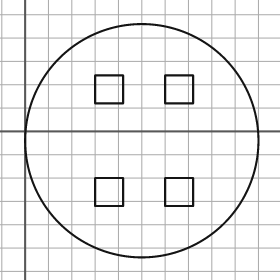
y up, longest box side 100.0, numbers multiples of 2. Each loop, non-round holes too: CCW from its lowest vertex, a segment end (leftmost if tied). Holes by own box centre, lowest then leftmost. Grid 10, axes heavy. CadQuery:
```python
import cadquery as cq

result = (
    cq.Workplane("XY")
    .moveTo(50.0, -4.0)
    .circle(50.0)
    .moveTo(30.0, -32.0)
    .lineTo(42.0, -32.0)
    .lineTo(42.0, -20.0)
    .lineTo(30.0, -20.0)
    .close()
    .moveTo(60.0, -32.0)
    .lineTo(72.0, -32.0)
    .lineTo(72.0, -20.0)
    .lineTo(60.0, -20.0)
    .close()
    .moveTo(30.0, 12.0)
    .lineTo(42.0, 12.0)
    .lineTo(42.0, 24.0)
    .lineTo(30.0, 24.0)
    .close()
    .moveTo(60.0, 12.0)
    .lineTo(72.0, 12.0)
    .lineTo(72.0, 24.0)
    .lineTo(60.0, 24.0)
    .close()
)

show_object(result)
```